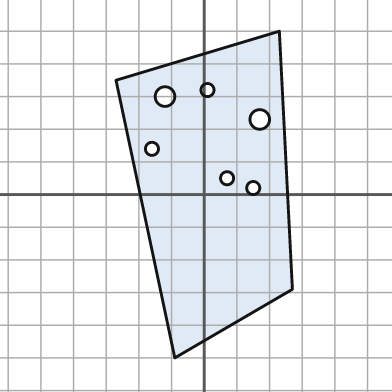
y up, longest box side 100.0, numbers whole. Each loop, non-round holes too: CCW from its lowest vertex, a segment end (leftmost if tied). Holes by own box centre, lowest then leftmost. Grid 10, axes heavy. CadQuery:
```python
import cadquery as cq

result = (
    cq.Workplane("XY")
    .moveTo(-9.0, -50.0)
    .lineTo(27.0, -29.0)
    .lineTo(23.0, 50.0)
    .lineTo(-27.0, 35.0)
    .close()
    .moveTo(15.0, 2.0)
    .circle(2.0)
    .moveTo(7.0, 5.0)
    .circle(2.0)
    .moveTo(-16.0, 14.0)
    .circle(2.0)
    .moveTo(17.0, 23.0)
    .circle(3.0)
    .moveTo(-12.0, 30.0)
    .circle(3.0)
    .moveTo(1.0, 32.0)
    .circle(2.0)
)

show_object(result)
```